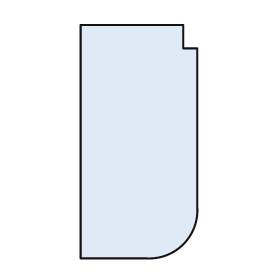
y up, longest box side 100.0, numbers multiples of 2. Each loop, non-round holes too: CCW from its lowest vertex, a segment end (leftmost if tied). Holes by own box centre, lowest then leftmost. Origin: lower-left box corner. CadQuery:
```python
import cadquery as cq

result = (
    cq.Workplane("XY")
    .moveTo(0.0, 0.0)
    .lineTo(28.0, 0.0)
    .threePointArc((44.0, 6.0), (50.0, 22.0))
    .lineTo(50.0, 90.0)
    .lineTo(44.0, 90.0)
    .lineTo(44.0, 100.0)
    .lineTo(0.0, 100.0)
    .close()
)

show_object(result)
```